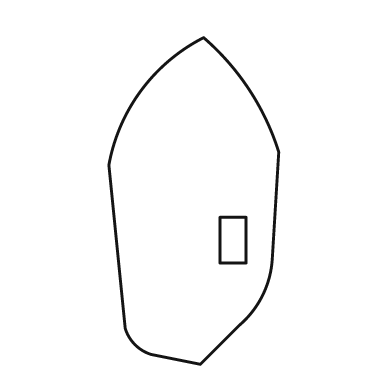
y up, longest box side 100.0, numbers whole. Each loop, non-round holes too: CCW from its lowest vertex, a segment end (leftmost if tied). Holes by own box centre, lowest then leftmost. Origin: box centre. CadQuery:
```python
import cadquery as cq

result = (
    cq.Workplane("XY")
    .moveTo(2.0, -50.0)
    .lineTo(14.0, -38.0)
    .threePointArc((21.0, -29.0), (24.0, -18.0))
    .lineTo(26.0, 15.0)
    .threePointArc((17.0, 34.0), (3.0, 50.0))
    .threePointArc((-16.0, 34.0), (-26.0, 11.0))
    .lineTo(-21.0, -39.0)
    .threePointArc((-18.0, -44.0), (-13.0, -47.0))
    .close()
    .moveTo(8.0, -19.0)
    .lineTo(16.0, -19.0)
    .lineTo(16.0, -5.0)
    .lineTo(8.0, -5.0)
    .close()
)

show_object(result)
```